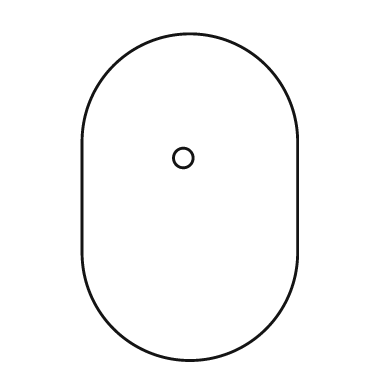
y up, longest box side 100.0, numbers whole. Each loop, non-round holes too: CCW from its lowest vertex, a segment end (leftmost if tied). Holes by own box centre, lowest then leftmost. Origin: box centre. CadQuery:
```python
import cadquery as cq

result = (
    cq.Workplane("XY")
    .moveTo(-33.0, -17.0)
    .threePointArc((0.0, -50.0), (33.0, -17.0))
    .lineTo(33.0, 17.0)
    .threePointArc((0.0, 50.0), (-33.0, 17.0))
    .close()
    .moveTo(-2.0, 12.0)
    .circle(3.0)
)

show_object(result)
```